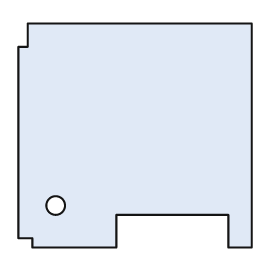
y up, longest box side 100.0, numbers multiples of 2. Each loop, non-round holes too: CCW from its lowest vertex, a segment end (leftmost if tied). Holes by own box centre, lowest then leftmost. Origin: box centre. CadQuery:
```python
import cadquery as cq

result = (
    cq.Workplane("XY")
    .moveTo(-44.0, -48.0)
    .lineTo(-8.0, -48.0)
    .lineTo(-8.0, -34.0)
    .lineTo(40.0, -34.0)
    .lineTo(40.0, -48.0)
    .lineTo(50.0, -48.0)
    .lineTo(50.0, 48.0)
    .lineTo(-46.0, 48.0)
    .lineTo(-46.0, 38.0)
    .lineTo(-50.0, 38.0)
    .lineTo(-50.0, -44.0)
    .lineTo(-44.0, -44.0)
    .close()
    .moveTo(-34.0, -30.0)
    .circle(4.0)
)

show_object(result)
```